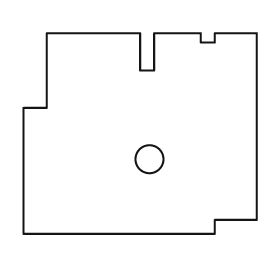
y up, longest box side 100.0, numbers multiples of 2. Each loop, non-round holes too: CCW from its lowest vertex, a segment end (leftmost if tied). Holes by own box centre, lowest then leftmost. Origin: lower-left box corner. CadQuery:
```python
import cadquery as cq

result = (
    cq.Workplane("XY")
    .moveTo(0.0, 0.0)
    .lineTo(82.0, 0.0)
    .lineTo(82.0, 6.0)
    .lineTo(100.0, 6.0)
    .lineTo(100.0, 86.0)
    .lineTo(82.0, 86.0)
    .lineTo(82.0, 82.0)
    .lineTo(76.0, 82.0)
    .lineTo(76.0, 86.0)
    .lineTo(56.0, 86.0)
    .lineTo(56.0, 70.0)
    .lineTo(50.0, 70.0)
    .lineTo(50.0, 86.0)
    .lineTo(10.0, 86.0)
    .lineTo(10.0, 54.0)
    .lineTo(0.0, 54.0)
    .close()
    .moveTo(54.0, 32.0)
    .circle(6.0)
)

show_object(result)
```